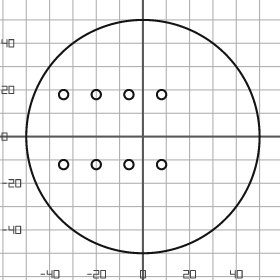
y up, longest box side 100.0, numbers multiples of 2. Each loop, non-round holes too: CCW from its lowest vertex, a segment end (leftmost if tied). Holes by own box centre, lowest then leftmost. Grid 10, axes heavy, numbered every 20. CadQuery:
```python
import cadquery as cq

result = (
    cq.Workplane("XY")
    .moveTo(0.0, 0.0)
    .circle(50.0)
    .moveTo(-34.0, -12.0)
    .circle(2.0)
    .moveTo(-20.0, -12.0)
    .circle(2.0)
    .moveTo(-6.0, -12.0)
    .circle(2.0)
    .moveTo(8.0, -12.0)
    .circle(2.0)
    .moveTo(-34.0, 18.0)
    .circle(2.0)
    .moveTo(-20.0, 18.0)
    .circle(2.0)
    .moveTo(-6.0, 18.0)
    .circle(2.0)
    .moveTo(8.0, 18.0)
    .circle(2.0)
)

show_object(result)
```